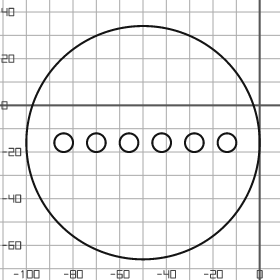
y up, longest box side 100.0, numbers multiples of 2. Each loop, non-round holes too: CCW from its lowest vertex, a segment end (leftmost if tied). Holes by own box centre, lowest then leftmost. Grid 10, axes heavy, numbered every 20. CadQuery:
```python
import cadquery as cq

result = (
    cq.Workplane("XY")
    .moveTo(-50.0, -16.0)
    .circle(50.0)
    .moveTo(-84.0, -16.0)
    .circle(4.0)
    .moveTo(-70.0, -16.0)
    .circle(4.0)
    .moveTo(-56.0, -16.0)
    .circle(4.0)
    .moveTo(-42.0, -16.0)
    .circle(4.0)
    .moveTo(-28.0, -16.0)
    .circle(4.0)
    .moveTo(-14.0, -16.0)
    .circle(4.0)
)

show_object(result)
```